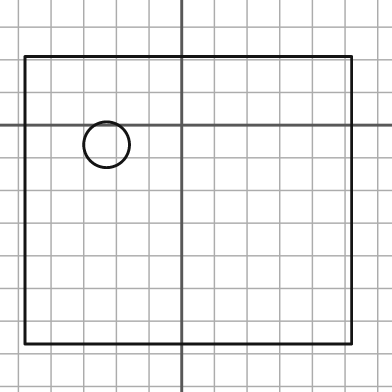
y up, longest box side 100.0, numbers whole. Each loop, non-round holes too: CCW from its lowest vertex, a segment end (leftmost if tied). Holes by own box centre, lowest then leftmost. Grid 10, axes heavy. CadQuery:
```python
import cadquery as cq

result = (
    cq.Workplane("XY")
    .moveTo(-48.0, -67.0)
    .lineTo(52.0, -67.0)
    .lineTo(52.0, 21.0)
    .lineTo(-48.0, 21.0)
    .close()
    .moveTo(-23.0, -6.0)
    .circle(7.0)
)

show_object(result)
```